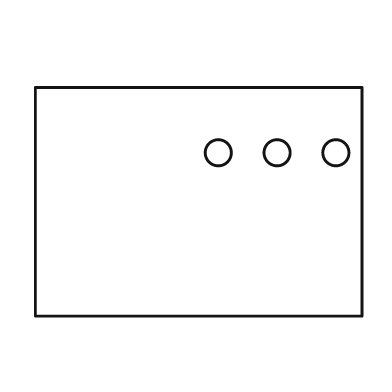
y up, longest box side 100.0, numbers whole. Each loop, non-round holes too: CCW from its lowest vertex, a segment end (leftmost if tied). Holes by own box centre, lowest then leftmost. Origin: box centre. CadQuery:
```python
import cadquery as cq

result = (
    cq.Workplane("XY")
    .moveTo(-50.0, -35.0)
    .lineTo(50.0, -35.0)
    .lineTo(50.0, 35.0)
    .lineTo(-50.0, 35.0)
    .close()
    .moveTo(6.0, 15.0)
    .circle(4.0)
    .moveTo(24.0, 15.0)
    .circle(4.0)
    .moveTo(42.0, 15.0)
    .circle(4.0)
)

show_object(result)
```